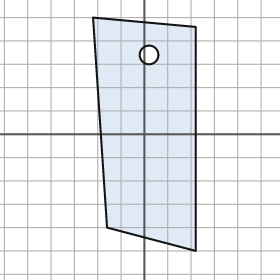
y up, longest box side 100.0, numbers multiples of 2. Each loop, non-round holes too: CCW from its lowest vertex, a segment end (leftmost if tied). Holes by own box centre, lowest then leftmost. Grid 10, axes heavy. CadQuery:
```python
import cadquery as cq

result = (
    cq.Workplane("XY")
    .moveTo(22.0, -50.0)
    .lineTo(22.0, 46.0)
    .lineTo(-22.0, 50.0)
    .lineTo(-16.0, -40.0)
    .close()
    .moveTo(2.0, 34.0)
    .circle(4.0)
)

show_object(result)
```